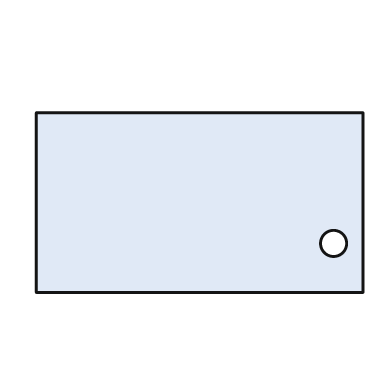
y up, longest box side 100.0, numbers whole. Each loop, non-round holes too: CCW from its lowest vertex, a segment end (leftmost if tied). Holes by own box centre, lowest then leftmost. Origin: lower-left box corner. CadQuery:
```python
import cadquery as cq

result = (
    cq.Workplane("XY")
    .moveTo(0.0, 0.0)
    .lineTo(100.0, 0.0)
    .lineTo(100.0, 55.0)
    .lineTo(0.0, 55.0)
    .close()
    .moveTo(91.0, 15.0)
    .circle(4.0)
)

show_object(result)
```